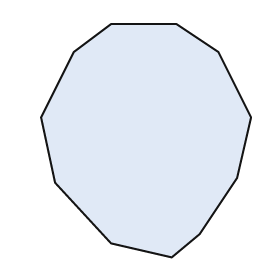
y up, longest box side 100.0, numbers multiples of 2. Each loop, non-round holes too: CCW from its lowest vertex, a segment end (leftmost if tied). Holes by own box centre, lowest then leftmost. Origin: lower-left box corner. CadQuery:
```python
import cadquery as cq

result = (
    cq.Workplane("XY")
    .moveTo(56.0, 0.0)
    .lineTo(68.0, 10.0)
    .lineTo(84.0, 34.0)
    .lineTo(90.0, 60.0)
    .lineTo(76.0, 88.0)
    .lineTo(58.0, 100.0)
    .lineTo(30.0, 100.0)
    .lineTo(14.0, 88.0)
    .lineTo(0.0, 60.0)
    .lineTo(6.0, 32.0)
    .lineTo(30.0, 6.0)
    .close()
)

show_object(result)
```